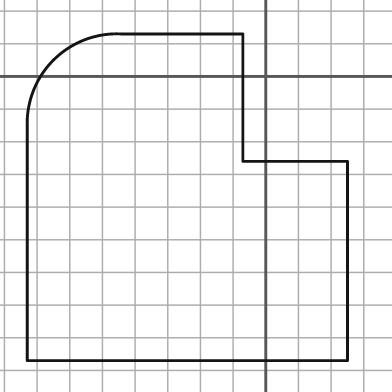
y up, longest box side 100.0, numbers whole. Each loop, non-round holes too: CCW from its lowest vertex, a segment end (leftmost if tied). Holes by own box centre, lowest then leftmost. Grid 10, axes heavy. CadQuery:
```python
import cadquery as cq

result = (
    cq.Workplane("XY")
    .moveTo(-73.0, -87.0)
    .lineTo(25.0, -87.0)
    .lineTo(25.0, -26.0)
    .lineTo(-7.0, -26.0)
    .lineTo(-7.0, 13.0)
    .lineTo(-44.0, 13.0)
    .threePointArc((-65.0, 5.0), (-73.0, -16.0))
    .close()
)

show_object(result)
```